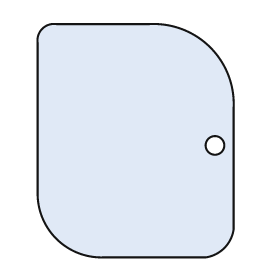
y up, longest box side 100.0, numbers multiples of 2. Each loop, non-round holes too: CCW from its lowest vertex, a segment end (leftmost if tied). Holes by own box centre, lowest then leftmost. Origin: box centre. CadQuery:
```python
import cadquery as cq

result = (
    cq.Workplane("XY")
    .moveTo(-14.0, -50.0)
    .lineTo(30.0, -50.0)
    .threePointArc((38.0, -46.0), (42.0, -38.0))
    .lineTo(42.0, 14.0)
    .threePointArc((32.0, 40.0), (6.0, 50.0))
    .lineTo(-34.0, 50.0)
    .threePointArc((-40.0, 48.0), (-42.0, 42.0))
    .lineTo(-42.0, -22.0)
    .threePointArc((-34.0, -42.0), (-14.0, -50.0))
    .close()
    .moveTo(34.0, -2.0)
    .circle(4.0)
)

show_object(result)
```